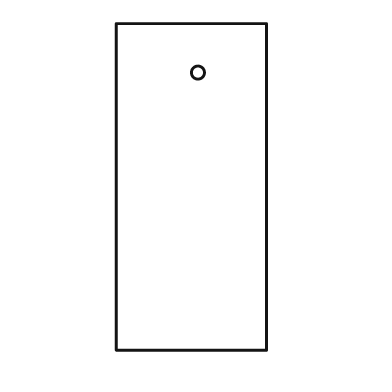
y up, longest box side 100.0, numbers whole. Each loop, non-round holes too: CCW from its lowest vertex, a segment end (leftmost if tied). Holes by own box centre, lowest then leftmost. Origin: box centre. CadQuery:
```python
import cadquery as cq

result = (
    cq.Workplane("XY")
    .moveTo(-23.0, -50.0)
    .lineTo(23.0, -50.0)
    .lineTo(23.0, 50.0)
    .lineTo(-23.0, 50.0)
    .close()
    .moveTo(2.0, 35.0)
    .circle(2.0)
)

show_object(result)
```